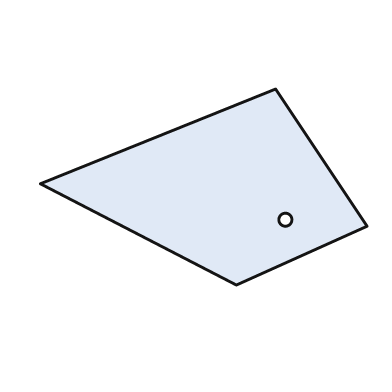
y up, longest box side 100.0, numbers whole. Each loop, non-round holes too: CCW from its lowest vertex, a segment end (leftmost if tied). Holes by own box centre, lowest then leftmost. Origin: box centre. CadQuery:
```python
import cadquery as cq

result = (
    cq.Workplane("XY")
    .moveTo(10.0, -30.0)
    .lineTo(50.0, -12.0)
    .lineTo(22.0, 30.0)
    .lineTo(-50.0, 1.0)
    .close()
    .moveTo(25.0, -10.0)
    .circle(2.0)
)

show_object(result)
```